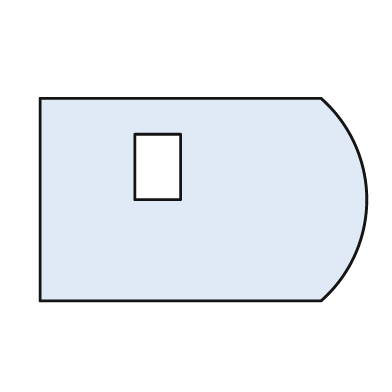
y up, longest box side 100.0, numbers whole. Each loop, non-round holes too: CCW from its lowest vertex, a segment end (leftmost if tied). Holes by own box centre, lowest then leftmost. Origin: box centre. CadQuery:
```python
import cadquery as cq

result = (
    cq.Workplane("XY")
    .moveTo(-50.0, -31.0)
    .lineTo(36.0, -31.0)
    .threePointArc((50.0, 0.0), (36.0, 31.0))
    .lineTo(-50.0, 31.0)
    .close()
    .moveTo(-21.0, 0.0)
    .lineTo(-7.0, 0.0)
    .lineTo(-7.0, 20.0)
    .lineTo(-21.0, 20.0)
    .close()
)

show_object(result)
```